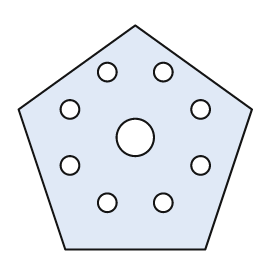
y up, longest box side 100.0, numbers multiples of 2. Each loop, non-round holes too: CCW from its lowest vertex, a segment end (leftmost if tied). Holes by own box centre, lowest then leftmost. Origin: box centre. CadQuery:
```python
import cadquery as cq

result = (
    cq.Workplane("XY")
    .moveTo(-30.0, -48.0)
    .lineTo(30.0, -48.0)
    .lineTo(50.0, 12.0)
    .lineTo(0.0, 48.0)
    .lineTo(-50.0, 12.0)
    .close()
    .moveTo(-12.0, -28.0)
    .circle(4.0)
    .moveTo(12.0, -28.0)
    .circle(4.0)
    .moveTo(-28.0, -12.0)
    .circle(4.0)
    .moveTo(28.0, -12.0)
    .circle(4.0)
    .moveTo(0.0, 0.0)
    .circle(8.0)
    .moveTo(-28.0, 12.0)
    .circle(4.0)
    .moveTo(28.0, 12.0)
    .circle(4.0)
    .moveTo(-12.0, 28.0)
    .circle(4.0)
    .moveTo(12.0, 28.0)
    .circle(4.0)
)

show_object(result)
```